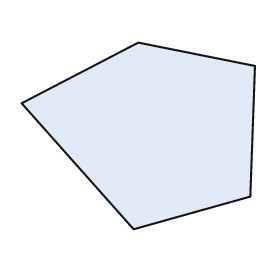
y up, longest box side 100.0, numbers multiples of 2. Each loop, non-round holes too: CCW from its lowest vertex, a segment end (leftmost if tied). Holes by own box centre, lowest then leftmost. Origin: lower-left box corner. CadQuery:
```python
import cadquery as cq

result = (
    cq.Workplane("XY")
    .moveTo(48.0, 0.0)
    .lineTo(98.0, 14.0)
    .lineTo(100.0, 70.0)
    .lineTo(50.0, 80.0)
    .lineTo(0.0, 54.0)
    .close()
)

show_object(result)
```